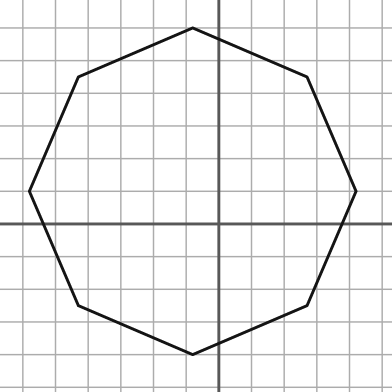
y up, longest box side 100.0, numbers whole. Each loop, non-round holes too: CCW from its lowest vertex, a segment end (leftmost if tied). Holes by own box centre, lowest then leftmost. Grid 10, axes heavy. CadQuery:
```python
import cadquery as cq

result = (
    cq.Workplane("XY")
    .moveTo(-8.0, -40.0)
    .lineTo(27.0, -25.0)
    .lineTo(42.0, 10.0)
    .lineTo(27.0, 45.0)
    .lineTo(-8.0, 60.0)
    .lineTo(-43.0, 45.0)
    .lineTo(-58.0, 10.0)
    .lineTo(-43.0, -25.0)
    .close()
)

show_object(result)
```